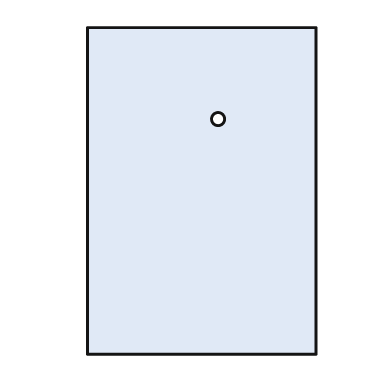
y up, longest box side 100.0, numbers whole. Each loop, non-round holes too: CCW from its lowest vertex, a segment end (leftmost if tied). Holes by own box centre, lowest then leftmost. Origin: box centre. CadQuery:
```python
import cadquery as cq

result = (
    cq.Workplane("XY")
    .moveTo(-35.0, -50.0)
    .lineTo(35.0, -50.0)
    .lineTo(35.0, 50.0)
    .lineTo(-35.0, 50.0)
    .close()
    .moveTo(5.0, 22.0)
    .circle(2.0)
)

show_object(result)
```